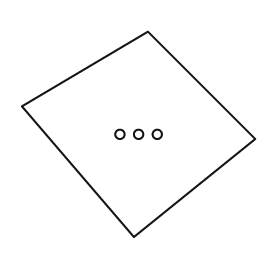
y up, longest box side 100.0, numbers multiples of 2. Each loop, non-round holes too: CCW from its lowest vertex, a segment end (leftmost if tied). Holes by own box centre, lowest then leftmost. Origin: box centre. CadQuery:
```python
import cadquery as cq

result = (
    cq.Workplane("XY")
    .moveTo(-2.0, -44.0)
    .lineTo(50.0, -2.0)
    .lineTo(4.0, 44.0)
    .lineTo(-50.0, 12.0)
    .close()
    .moveTo(-8.0, 0.0)
    .circle(2.0)
    .moveTo(0.0, 0.0)
    .circle(2.0)
    .moveTo(8.0, 0.0)
    .circle(2.0)
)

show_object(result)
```